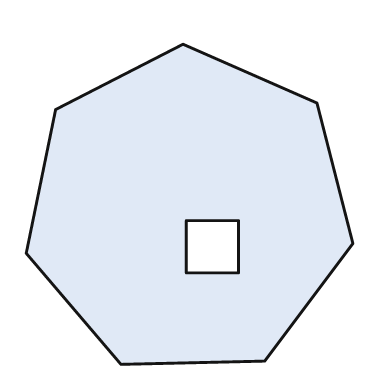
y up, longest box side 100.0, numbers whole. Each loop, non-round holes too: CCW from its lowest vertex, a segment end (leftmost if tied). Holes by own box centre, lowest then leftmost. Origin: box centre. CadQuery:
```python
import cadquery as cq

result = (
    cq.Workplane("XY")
    .moveTo(-21.0, -49.0)
    .lineTo(23.0, -48.0)
    .lineTo(50.0, -12.0)
    .lineTo(39.0, 31.0)
    .lineTo(-2.0, 49.0)
    .lineTo(-41.0, 29.0)
    .lineTo(-50.0, -15.0)
    .close()
    .moveTo(-1.0, -21.0)
    .lineTo(15.0, -21.0)
    .lineTo(15.0, -5.0)
    .lineTo(-1.0, -5.0)
    .close()
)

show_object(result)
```